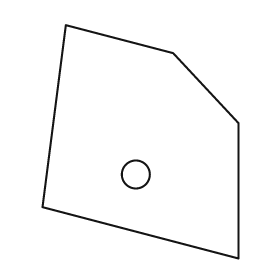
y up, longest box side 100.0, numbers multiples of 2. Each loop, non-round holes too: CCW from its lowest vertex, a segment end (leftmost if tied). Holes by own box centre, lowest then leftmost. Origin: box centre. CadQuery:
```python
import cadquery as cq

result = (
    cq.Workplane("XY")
    .moveTo(42.0, -50.0)
    .lineTo(42.0, 8.0)
    .lineTo(14.0, 38.0)
    .lineTo(-32.0, 50.0)
    .lineTo(-42.0, -28.0)
    .close()
    .moveTo(-2.0, -14.0)
    .circle(6.0)
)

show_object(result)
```